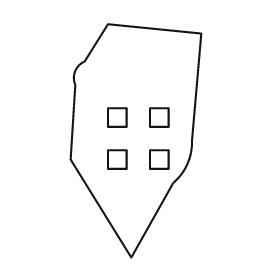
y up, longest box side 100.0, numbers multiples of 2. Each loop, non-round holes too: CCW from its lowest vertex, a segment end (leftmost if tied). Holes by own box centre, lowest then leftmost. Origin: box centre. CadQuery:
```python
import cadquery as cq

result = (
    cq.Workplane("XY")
    .moveTo(-2.0, -50.0)
    .lineTo(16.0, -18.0)
    .threePointArc((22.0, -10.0), (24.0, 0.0))
    .lineTo(28.0, 46.0)
    .lineTo(-12.0, 50.0)
    .lineTo(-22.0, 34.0)
    .threePointArc((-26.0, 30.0), (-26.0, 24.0))
    .lineTo(-28.0, -8.0)
    .close()
    .moveTo(-12.0, -12.0)
    .lineTo(-4.0, -12.0)
    .lineTo(-4.0, -4.0)
    .lineTo(-12.0, -4.0)
    .close()
    .moveTo(6.0, -12.0)
    .lineTo(14.0, -12.0)
    .lineTo(14.0, -4.0)
    .lineTo(6.0, -4.0)
    .close()
    .moveTo(-12.0, 6.0)
    .lineTo(-4.0, 6.0)
    .lineTo(-4.0, 14.0)
    .lineTo(-12.0, 14.0)
    .close()
    .moveTo(6.0, 6.0)
    .lineTo(14.0, 6.0)
    .lineTo(14.0, 14.0)
    .lineTo(6.0, 14.0)
    .close()
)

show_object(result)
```